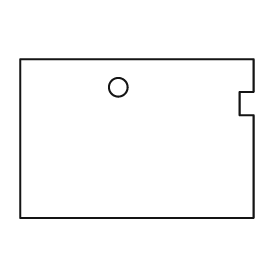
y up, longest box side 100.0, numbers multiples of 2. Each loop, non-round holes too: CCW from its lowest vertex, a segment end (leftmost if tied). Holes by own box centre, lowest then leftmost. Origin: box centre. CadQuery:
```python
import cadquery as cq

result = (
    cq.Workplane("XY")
    .moveTo(-50.0, -34.0)
    .lineTo(50.0, -34.0)
    .lineTo(50.0, 10.0)
    .lineTo(44.0, 10.0)
    .lineTo(44.0, 20.0)
    .lineTo(50.0, 20.0)
    .lineTo(50.0, 34.0)
    .lineTo(-50.0, 34.0)
    .close()
    .moveTo(-8.0, 22.0)
    .circle(4.0)
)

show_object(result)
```